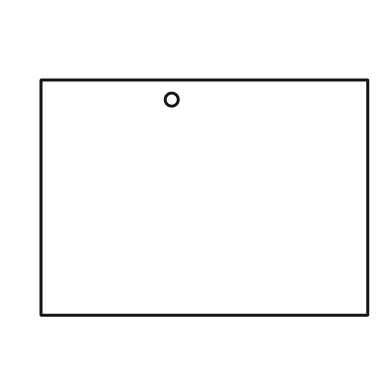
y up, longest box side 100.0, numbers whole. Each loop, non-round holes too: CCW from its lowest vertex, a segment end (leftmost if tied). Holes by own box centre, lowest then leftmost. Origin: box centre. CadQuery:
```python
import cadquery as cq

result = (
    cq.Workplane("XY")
    .moveTo(-50.0, -36.0)
    .lineTo(50.0, -36.0)
    .lineTo(50.0, 36.0)
    .lineTo(-50.0, 36.0)
    .close()
    .moveTo(-10.0, 30.0)
    .circle(2.0)
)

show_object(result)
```